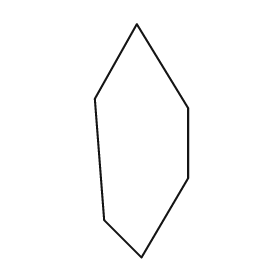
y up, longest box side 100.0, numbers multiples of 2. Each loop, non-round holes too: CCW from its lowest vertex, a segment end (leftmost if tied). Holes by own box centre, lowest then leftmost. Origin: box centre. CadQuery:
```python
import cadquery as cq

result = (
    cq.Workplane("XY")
    .moveTo(0.0, -50.0)
    .lineTo(20.0, -16.0)
    .lineTo(20.0, 14.0)
    .lineTo(-2.0, 50.0)
    .lineTo(-20.0, 18.0)
    .lineTo(-16.0, -34.0)
    .close()
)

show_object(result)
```